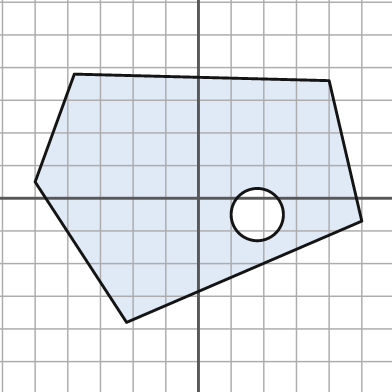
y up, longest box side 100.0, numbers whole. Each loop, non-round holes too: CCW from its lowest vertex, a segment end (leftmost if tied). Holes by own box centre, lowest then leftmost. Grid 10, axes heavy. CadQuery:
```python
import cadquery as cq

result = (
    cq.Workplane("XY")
    .moveTo(-22.0, -38.0)
    .lineTo(50.0, -7.0)
    .lineTo(40.0, 36.0)
    .lineTo(-38.0, 38.0)
    .lineTo(-50.0, 5.0)
    .close()
    .moveTo(18.0, -5.0)
    .circle(8.0)
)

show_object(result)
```